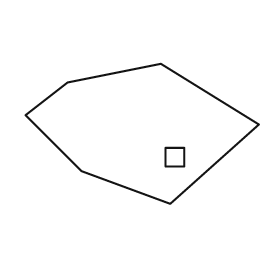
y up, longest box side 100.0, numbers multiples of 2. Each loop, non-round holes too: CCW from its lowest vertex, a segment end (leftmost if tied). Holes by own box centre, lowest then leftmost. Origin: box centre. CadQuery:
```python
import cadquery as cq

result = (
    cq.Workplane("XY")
    .moveTo(12.0, -30.0)
    .lineTo(50.0, 4.0)
    .lineTo(8.0, 30.0)
    .lineTo(-32.0, 22.0)
    .lineTo(-50.0, 8.0)
    .lineTo(-26.0, -16.0)
    .close()
    .moveTo(10.0, -14.0)
    .lineTo(18.0, -14.0)
    .lineTo(18.0, -6.0)
    .lineTo(10.0, -6.0)
    .close()
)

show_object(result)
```